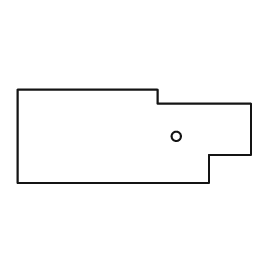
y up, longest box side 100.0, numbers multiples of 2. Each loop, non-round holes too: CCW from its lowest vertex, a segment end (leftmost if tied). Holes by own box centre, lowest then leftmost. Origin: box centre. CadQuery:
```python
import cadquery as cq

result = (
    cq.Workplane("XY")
    .moveTo(-50.0, -20.0)
    .lineTo(32.0, -20.0)
    .lineTo(32.0, -8.0)
    .lineTo(50.0, -8.0)
    .lineTo(50.0, 14.0)
    .lineTo(10.0, 14.0)
    .lineTo(10.0, 20.0)
    .lineTo(-50.0, 20.0)
    .close()
    .moveTo(18.0, 0.0)
    .circle(2.0)
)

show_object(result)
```